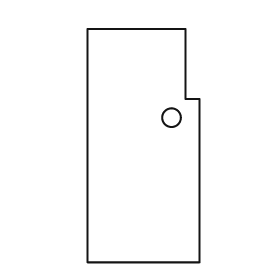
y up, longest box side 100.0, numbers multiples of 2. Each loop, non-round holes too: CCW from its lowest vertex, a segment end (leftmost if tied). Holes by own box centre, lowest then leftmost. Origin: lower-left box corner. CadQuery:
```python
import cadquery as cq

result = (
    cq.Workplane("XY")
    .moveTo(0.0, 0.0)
    .lineTo(48.0, 0.0)
    .lineTo(48.0, 70.0)
    .lineTo(42.0, 70.0)
    .lineTo(42.0, 100.0)
    .lineTo(0.0, 100.0)
    .close()
    .moveTo(36.0, 62.0)
    .circle(4.0)
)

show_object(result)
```